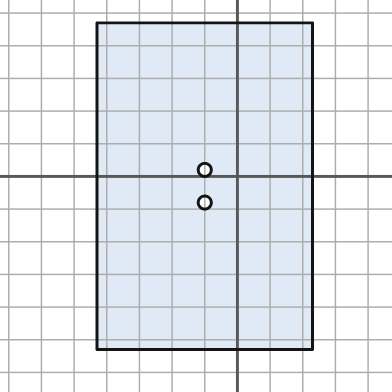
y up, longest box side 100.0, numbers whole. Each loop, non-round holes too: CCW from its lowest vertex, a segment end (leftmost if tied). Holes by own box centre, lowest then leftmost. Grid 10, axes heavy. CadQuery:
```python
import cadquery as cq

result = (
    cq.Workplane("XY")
    .moveTo(-43.0, -53.0)
    .lineTo(23.0, -53.0)
    .lineTo(23.0, 47.0)
    .lineTo(-43.0, 47.0)
    .close()
    .moveTo(-10.0, -8.0)
    .circle(2.0)
    .moveTo(-10.0, 2.0)
    .circle(2.0)
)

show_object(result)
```